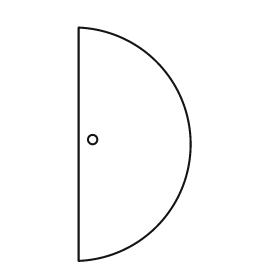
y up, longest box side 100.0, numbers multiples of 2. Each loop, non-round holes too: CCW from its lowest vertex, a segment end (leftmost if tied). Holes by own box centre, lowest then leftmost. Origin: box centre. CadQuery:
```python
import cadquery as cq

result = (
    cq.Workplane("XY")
    .moveTo(-24.0, -50.0)
    .threePointArc((24.0, 0.0), (-24.0, 50.0))
    .close()
    .moveTo(-18.0, 2.0)
    .circle(2.0)
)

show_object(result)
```